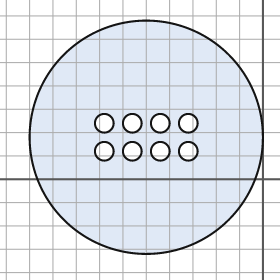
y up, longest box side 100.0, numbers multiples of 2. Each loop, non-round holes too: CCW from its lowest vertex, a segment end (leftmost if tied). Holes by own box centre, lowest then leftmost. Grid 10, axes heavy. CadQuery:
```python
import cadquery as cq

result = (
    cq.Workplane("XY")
    .moveTo(-50.0, 18.0)
    .circle(50.0)
    .moveTo(-68.0, 12.0)
    .circle(4.0)
    .moveTo(-56.0, 12.0)
    .circle(4.0)
    .moveTo(-44.0, 12.0)
    .circle(4.0)
    .moveTo(-32.0, 12.0)
    .circle(4.0)
    .moveTo(-68.0, 24.0)
    .circle(4.0)
    .moveTo(-56.0, 24.0)
    .circle(4.0)
    .moveTo(-44.0, 24.0)
    .circle(4.0)
    .moveTo(-32.0, 24.0)
    .circle(4.0)
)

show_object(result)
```